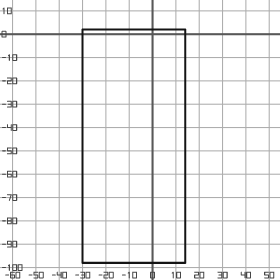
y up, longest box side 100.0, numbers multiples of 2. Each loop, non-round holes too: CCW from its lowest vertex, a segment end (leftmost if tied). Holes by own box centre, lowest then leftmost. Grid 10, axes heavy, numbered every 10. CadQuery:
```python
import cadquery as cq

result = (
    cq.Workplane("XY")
    .moveTo(-30.0, -98.0)
    .lineTo(14.0, -98.0)
    .lineTo(14.0, 2.0)
    .lineTo(-30.0, 2.0)
    .close()
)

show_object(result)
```